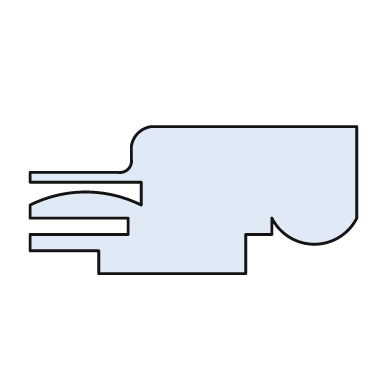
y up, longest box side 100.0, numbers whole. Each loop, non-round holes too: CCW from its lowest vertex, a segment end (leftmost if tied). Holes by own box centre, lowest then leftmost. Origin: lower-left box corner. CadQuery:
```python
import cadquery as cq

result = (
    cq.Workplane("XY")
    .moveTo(21.0, 0.0)
    .lineTo(66.0, 0.0)
    .lineTo(66.0, 12.0)
    .lineTo(74.0, 12.0)
    .lineTo(74.0, 17.0)
    .threePointArc((87.0, 9.0), (100.0, 17.0))
    .lineTo(100.0, 45.0)
    .lineTo(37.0, 45.0)
    .threePointArc((33.0, 43.0), (31.0, 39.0))
    .lineTo(31.0, 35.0)
    .threePointArc((30.0, 32.0), (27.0, 31.0))
    .lineTo(0.0, 31.0)
    .lineTo(0.0, 28.0)
    .lineTo(34.0, 28.0)
    .lineTo(34.0, 21.0)
    .threePointArc((17.0, 25.0), (0.0, 21.0))
    .lineTo(0.0, 17.0)
    .lineTo(30.0, 17.0)
    .lineTo(30.0, 12.0)
    .lineTo(0.0, 12.0)
    .lineTo(0.0, 7.0)
    .lineTo(21.0, 7.0)
    .close()
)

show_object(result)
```